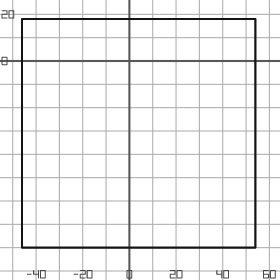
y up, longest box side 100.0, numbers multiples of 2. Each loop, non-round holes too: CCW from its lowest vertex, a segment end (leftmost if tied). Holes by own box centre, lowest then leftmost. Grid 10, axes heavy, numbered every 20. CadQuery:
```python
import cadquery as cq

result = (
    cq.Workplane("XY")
    .moveTo(-46.0, -80.0)
    .lineTo(54.0, -80.0)
    .lineTo(54.0, 18.0)
    .lineTo(-46.0, 18.0)
    .close()
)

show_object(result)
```